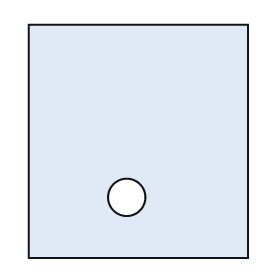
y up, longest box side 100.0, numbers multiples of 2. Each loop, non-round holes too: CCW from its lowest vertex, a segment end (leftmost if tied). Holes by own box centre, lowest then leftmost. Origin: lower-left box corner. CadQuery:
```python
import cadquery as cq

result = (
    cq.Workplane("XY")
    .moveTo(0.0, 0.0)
    .lineTo(94.0, 0.0)
    .lineTo(94.0, 100.0)
    .lineTo(0.0, 100.0)
    .close()
    .moveTo(42.0, 26.0)
    .circle(8.0)
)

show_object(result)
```